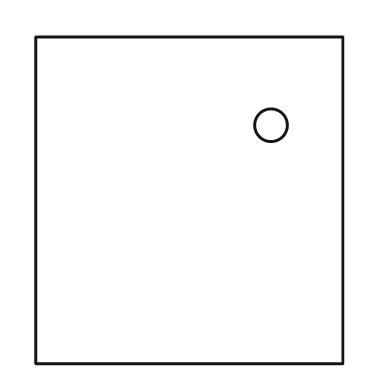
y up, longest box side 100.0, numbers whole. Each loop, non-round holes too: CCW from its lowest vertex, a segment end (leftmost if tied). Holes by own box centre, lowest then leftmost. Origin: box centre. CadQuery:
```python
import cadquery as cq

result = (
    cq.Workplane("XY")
    .moveTo(-47.0, -50.0)
    .lineTo(47.0, -50.0)
    .lineTo(47.0, 50.0)
    .lineTo(-47.0, 50.0)
    .close()
    .moveTo(25.0, 23.0)
    .circle(5.0)
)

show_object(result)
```